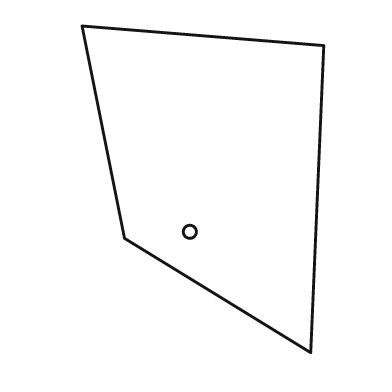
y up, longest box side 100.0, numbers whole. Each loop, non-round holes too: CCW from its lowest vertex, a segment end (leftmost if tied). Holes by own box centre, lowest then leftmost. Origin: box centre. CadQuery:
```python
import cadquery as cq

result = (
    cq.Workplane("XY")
    .moveTo(33.0, -50.0)
    .lineTo(37.0, 44.0)
    .lineTo(-37.0, 50.0)
    .lineTo(-24.0, -15.0)
    .close()
    .moveTo(-4.0, -13.0)
    .circle(2.0)
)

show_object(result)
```